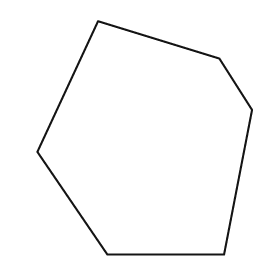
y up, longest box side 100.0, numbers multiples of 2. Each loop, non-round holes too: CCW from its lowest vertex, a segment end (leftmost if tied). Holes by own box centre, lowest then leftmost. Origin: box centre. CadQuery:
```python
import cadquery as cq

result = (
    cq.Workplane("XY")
    .moveTo(-16.0, -50.0)
    .lineTo(34.0, -50.0)
    .lineTo(46.0, 12.0)
    .lineTo(32.0, 34.0)
    .lineTo(-20.0, 50.0)
    .lineTo(-46.0, -6.0)
    .close()
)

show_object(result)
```